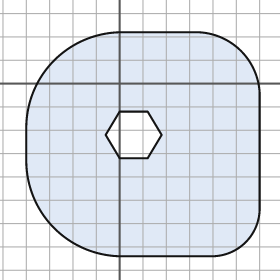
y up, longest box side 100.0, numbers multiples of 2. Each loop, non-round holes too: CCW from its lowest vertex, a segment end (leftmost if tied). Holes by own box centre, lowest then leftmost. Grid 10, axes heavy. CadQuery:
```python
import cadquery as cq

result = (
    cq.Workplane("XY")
    .moveTo(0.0, -74.0)
    .lineTo(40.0, -74.0)
    .threePointArc((54.0, -68.0), (60.0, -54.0))
    .lineTo(60.0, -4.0)
    .threePointArc((52.0, 14.0), (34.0, 22.0))
    .lineTo(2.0, 22.0)
    .threePointArc((-28.0, 10.0), (-40.0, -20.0))
    .lineTo(-40.0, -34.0)
    .threePointArc((-28.0, -62.0), (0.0, -74.0))
    .close()
    .moveTo(0.0, -32.0)
    .lineTo(12.0, -32.0)
    .lineTo(18.0, -22.0)
    .lineTo(12.0, -12.0)
    .lineTo(0.0, -12.0)
    .lineTo(-6.0, -22.0)
    .close()
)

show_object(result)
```